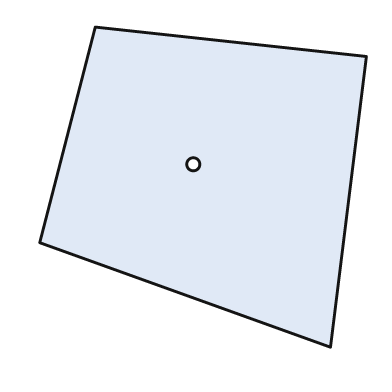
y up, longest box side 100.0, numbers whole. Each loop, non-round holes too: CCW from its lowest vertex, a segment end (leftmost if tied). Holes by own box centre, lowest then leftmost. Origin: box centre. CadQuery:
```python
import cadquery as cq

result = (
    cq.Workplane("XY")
    .moveTo(39.0, -49.0)
    .lineTo(50.0, 40.0)
    .lineTo(-33.0, 49.0)
    .lineTo(-50.0, -17.0)
    .close()
    .moveTo(-3.0, 7.0)
    .circle(2.0)
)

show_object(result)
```